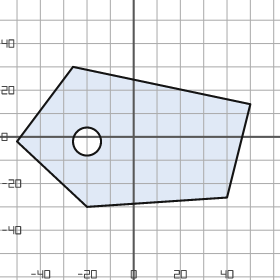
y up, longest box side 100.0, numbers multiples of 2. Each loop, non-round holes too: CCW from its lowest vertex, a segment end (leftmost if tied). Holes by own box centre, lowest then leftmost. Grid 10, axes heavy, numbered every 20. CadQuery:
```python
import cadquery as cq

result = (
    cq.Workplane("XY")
    .moveTo(-20.0, -30.0)
    .lineTo(40.0, -26.0)
    .lineTo(50.0, 14.0)
    .lineTo(-26.0, 30.0)
    .lineTo(-50.0, -2.0)
    .close()
    .moveTo(-20.0, -2.0)
    .circle(6.0)
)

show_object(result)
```